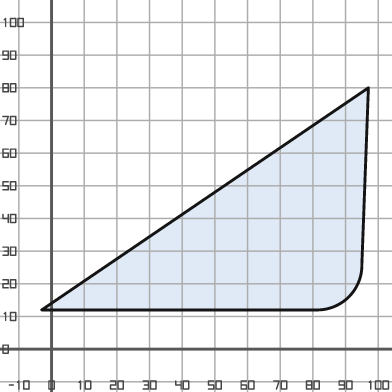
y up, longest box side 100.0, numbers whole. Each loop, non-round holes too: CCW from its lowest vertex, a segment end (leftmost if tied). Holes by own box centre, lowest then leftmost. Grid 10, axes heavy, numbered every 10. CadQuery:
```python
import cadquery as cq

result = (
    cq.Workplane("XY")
    .moveTo(-3.0, 12.0)
    .lineTo(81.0, 12.0)
    .threePointArc((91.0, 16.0), (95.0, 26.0))
    .lineTo(97.0, 80.0)
    .close()
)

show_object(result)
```